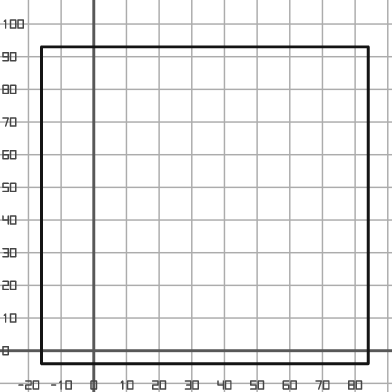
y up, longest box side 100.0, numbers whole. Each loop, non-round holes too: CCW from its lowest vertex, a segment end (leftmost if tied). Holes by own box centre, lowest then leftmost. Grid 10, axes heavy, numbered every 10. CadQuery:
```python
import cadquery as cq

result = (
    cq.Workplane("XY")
    .moveTo(-16.0, -4.0)
    .lineTo(84.0, -4.0)
    .lineTo(84.0, 93.0)
    .lineTo(-16.0, 93.0)
    .close()
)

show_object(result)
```